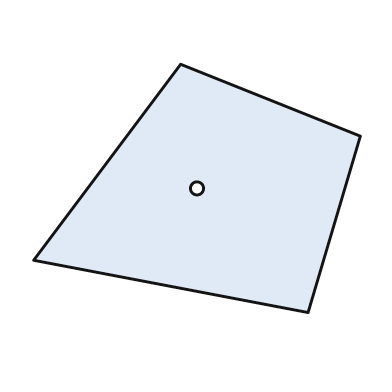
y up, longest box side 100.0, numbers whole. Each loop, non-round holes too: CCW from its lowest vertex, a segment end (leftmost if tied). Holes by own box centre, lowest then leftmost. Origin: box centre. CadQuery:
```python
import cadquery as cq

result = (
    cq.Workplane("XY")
    .moveTo(34.0, -38.0)
    .lineTo(50.0, 16.0)
    .lineTo(-5.0, 38.0)
    .lineTo(-50.0, -22.0)
    .close()
    .moveTo(0.0, 0.0)
    .circle(2.0)
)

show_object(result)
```